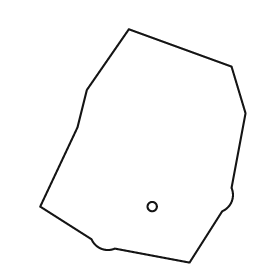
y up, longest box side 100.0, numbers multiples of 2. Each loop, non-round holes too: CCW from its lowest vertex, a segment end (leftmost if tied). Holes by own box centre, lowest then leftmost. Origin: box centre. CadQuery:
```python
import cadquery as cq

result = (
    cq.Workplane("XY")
    .moveTo(20.0, -50.0)
    .lineTo(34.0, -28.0)
    .threePointArc((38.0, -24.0), (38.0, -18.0))
    .lineTo(44.0, 14.0)
    .lineTo(38.0, 34.0)
    .lineTo(-6.0, 50.0)
    .lineTo(-24.0, 24.0)
    .lineTo(-28.0, 8.0)
    .lineTo(-44.0, -26.0)
    .lineTo(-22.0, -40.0)
    .threePointArc((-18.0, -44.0), (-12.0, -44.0))
    .close()
    .moveTo(4.0, -26.0)
    .circle(2.0)
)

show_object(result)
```